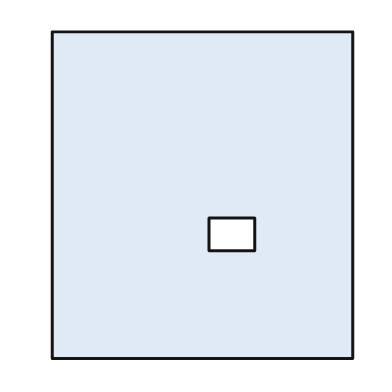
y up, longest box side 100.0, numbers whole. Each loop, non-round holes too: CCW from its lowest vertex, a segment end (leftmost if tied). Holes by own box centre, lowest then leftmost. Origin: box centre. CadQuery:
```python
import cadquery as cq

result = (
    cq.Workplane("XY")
    .moveTo(-46.0, -50.0)
    .lineTo(46.0, -50.0)
    .lineTo(46.0, 50.0)
    .lineTo(-46.0, 50.0)
    .close()
    .moveTo(2.0, -17.0)
    .lineTo(16.0, -17.0)
    .lineTo(16.0, -7.0)
    .lineTo(2.0, -7.0)
    .close()
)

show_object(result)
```